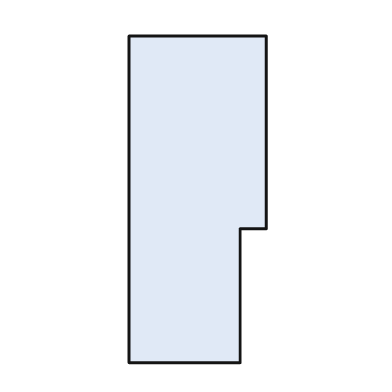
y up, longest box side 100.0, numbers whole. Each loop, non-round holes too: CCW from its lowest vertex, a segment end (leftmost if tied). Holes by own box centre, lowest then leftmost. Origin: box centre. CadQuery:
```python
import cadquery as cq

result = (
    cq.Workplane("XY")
    .moveTo(-21.0, -50.0)
    .lineTo(13.0, -50.0)
    .lineTo(13.0, -9.0)
    .lineTo(21.0, -9.0)
    .lineTo(21.0, 50.0)
    .lineTo(-21.0, 50.0)
    .close()
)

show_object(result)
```